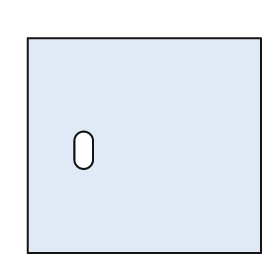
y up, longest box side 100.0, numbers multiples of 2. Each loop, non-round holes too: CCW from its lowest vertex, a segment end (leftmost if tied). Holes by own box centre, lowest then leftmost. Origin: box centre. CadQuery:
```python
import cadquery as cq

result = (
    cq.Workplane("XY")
    .moveTo(-50.0, -46.0)
    .lineTo(50.0, -46.0)
    .lineTo(50.0, 46.0)
    .lineTo(-50.0, 46.0)
    .close()
    .moveTo(-30.0, -6.0)
    .threePointArc((-26.0, -10.0), (-22.0, -6.0))
    .lineTo(-22.0, 2.0)
    .threePointArc((-26.0, 6.0), (-30.0, 2.0))
    .close()
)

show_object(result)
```